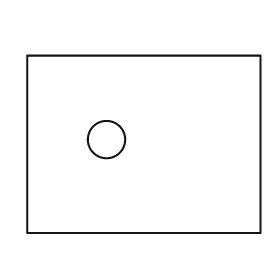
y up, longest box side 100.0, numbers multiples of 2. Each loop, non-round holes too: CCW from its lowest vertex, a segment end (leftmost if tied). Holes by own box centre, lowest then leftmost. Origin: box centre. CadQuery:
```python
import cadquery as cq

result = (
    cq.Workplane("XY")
    .moveTo(-50.0, -38.0)
    .lineTo(50.0, -38.0)
    .lineTo(50.0, 38.0)
    .lineTo(-50.0, 38.0)
    .close()
    .moveTo(-16.0, 2.0)
    .circle(8.0)
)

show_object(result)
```